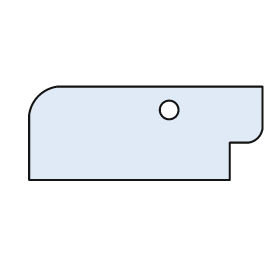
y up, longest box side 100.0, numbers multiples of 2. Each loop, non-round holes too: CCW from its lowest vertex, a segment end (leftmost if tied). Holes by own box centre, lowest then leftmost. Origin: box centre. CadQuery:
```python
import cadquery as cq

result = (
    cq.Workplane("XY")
    .moveTo(-50.0, -20.0)
    .lineTo(36.0, -20.0)
    .lineTo(36.0, -4.0)
    .lineTo(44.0, -4.0)
    .threePointArc((48.0, -2.0), (50.0, 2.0))
    .lineTo(50.0, 20.0)
    .lineTo(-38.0, 20.0)
    .threePointArc((-46.0, 16.0), (-50.0, 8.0))
    .close()
    .moveTo(10.0, 10.0)
    .circle(4.0)
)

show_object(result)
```